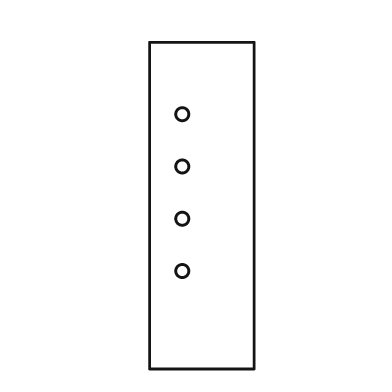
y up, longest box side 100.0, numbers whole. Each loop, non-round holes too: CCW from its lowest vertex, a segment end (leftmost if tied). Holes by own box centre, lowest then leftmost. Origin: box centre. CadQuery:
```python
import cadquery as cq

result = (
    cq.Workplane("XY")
    .moveTo(-16.0, -50.0)
    .lineTo(16.0, -50.0)
    .lineTo(16.0, 50.0)
    .lineTo(-16.0, 50.0)
    .close()
    .moveTo(-6.0, -20.0)
    .circle(2.0)
    .moveTo(-6.0, -4.0)
    .circle(2.0)
    .moveTo(-6.0, 12.0)
    .circle(2.0)
    .moveTo(-6.0, 28.0)
    .circle(2.0)
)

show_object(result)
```